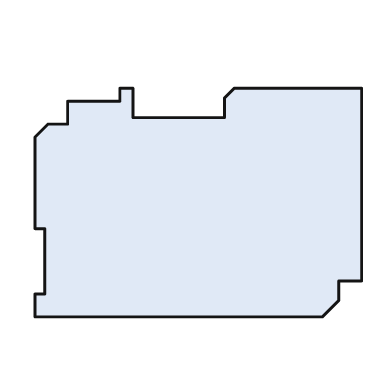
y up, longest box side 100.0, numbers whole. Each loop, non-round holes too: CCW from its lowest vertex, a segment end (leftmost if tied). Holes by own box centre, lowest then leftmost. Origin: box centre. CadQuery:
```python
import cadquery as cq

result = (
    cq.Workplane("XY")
    .moveTo(-50.0, -35.0)
    .lineTo(38.0, -35.0)
    .lineTo(43.0, -30.0)
    .lineTo(43.0, -24.0)
    .lineTo(50.0, -24.0)
    .lineTo(50.0, 35.0)
    .lineTo(11.0, 35.0)
    .lineTo(8.0, 32.0)
    .lineTo(8.0, 26.0)
    .lineTo(-20.0, 26.0)
    .lineTo(-20.0, 35.0)
    .lineTo(-24.0, 35.0)
    .lineTo(-24.0, 31.0)
    .lineTo(-40.0, 31.0)
    .lineTo(-40.0, 24.0)
    .lineTo(-46.0, 24.0)
    .lineTo(-50.0, 20.0)
    .lineTo(-50.0, -8.0)
    .lineTo(-47.0, -8.0)
    .lineTo(-47.0, -28.0)
    .lineTo(-50.0, -28.0)
    .close()
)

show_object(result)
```